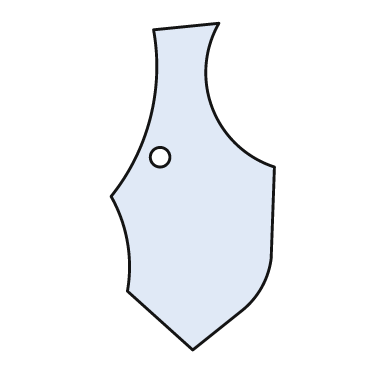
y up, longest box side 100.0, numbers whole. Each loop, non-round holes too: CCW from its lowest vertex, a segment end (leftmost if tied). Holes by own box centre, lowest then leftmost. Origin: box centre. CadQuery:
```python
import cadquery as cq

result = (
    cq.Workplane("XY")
    .moveTo(0.0, -50.0)
    .lineTo(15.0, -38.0)
    .threePointArc((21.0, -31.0), (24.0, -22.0))
    .lineTo(25.0, 6.0)
    .threePointArc((6.0, 24.0), (8.0, 50.0))
    .lineTo(-12.0, 48.0)
    .threePointArc((-13.0, 21.0), (-25.0, -3.0))
    .threePointArc((-20.0, -17.0), (-20.0, -32.0))
    .close()
    .moveTo(-10.0, 9.0)
    .circle(3.0)
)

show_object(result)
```